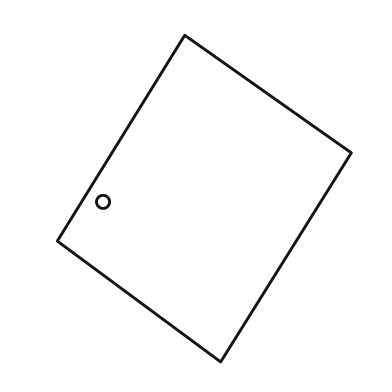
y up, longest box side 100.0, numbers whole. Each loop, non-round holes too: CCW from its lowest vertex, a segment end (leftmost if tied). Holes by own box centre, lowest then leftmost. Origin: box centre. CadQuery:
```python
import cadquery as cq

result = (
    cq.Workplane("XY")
    .moveTo(5.0, -50.0)
    .lineTo(45.0, 14.0)
    .lineTo(-6.0, 50.0)
    .lineTo(-45.0, -13.0)
    .close()
    .moveTo(-31.0, -1.0)
    .circle(2.0)
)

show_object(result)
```